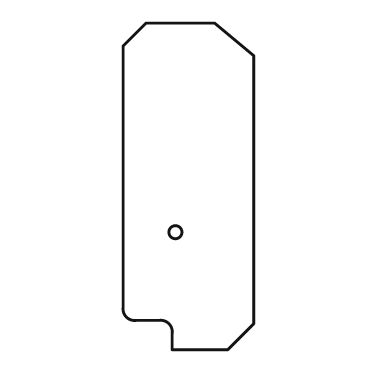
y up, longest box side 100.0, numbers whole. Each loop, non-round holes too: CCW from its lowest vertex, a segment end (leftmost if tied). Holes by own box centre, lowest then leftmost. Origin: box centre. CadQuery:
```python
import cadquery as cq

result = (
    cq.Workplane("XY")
    .moveTo(-5.0, -50.0)
    .lineTo(12.0, -50.0)
    .lineTo(20.0, -42.0)
    .lineTo(20.0, 40.0)
    .lineTo(8.0, 50.0)
    .lineTo(-13.0, 50.0)
    .lineTo(-20.0, 43.0)
    .lineTo(-20.0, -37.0)
    .threePointArc((-19.0, -40.0), (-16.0, -41.0))
    .lineTo(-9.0, -41.0)
    .threePointArc((-6.0, -42.0), (-5.0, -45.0))
    .close()
    .moveTo(-4.0, -14.0)
    .circle(2.0)
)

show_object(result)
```